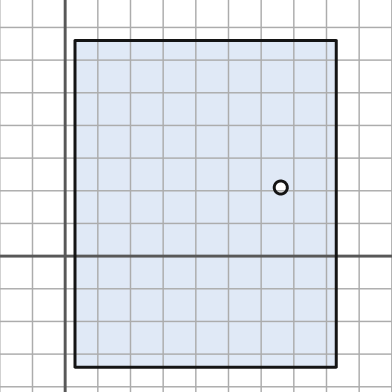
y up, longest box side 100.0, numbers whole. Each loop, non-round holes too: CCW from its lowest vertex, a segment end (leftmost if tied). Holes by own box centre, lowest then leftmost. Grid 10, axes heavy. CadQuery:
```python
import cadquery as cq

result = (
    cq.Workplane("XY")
    .moveTo(3.0, -34.0)
    .lineTo(83.0, -34.0)
    .lineTo(83.0, 66.0)
    .lineTo(3.0, 66.0)
    .close()
    .moveTo(66.0, 21.0)
    .circle(2.0)
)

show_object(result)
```